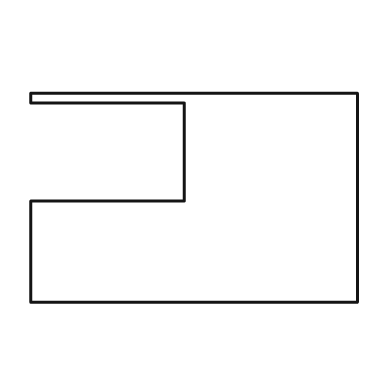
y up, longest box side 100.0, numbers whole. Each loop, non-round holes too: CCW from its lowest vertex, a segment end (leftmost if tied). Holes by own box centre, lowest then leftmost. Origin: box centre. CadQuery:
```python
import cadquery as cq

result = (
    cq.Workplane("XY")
    .moveTo(-50.0, -32.0)
    .lineTo(50.0, -32.0)
    .lineTo(50.0, 32.0)
    .lineTo(-50.0, 32.0)
    .lineTo(-50.0, 29.0)
    .lineTo(-3.0, 29.0)
    .lineTo(-3.0, -1.0)
    .lineTo(-50.0, -1.0)
    .close()
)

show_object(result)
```